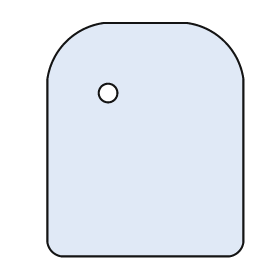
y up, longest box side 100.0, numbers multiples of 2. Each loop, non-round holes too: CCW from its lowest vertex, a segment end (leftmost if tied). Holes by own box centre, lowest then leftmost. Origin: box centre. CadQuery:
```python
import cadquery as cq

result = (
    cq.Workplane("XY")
    .moveTo(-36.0, -50.0)
    .lineTo(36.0, -50.0)
    .threePointArc((40.0, -48.0), (42.0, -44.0))
    .lineTo(42.0, 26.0)
    .threePointArc((34.0, 42.0), (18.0, 50.0))
    .lineTo(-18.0, 50.0)
    .threePointArc((-34.0, 42.0), (-42.0, 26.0))
    .lineTo(-42.0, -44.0)
    .threePointArc((-40.0, -48.0), (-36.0, -50.0))
    .close()
    .moveTo(-16.0, 20.0)
    .circle(4.0)
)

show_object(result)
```